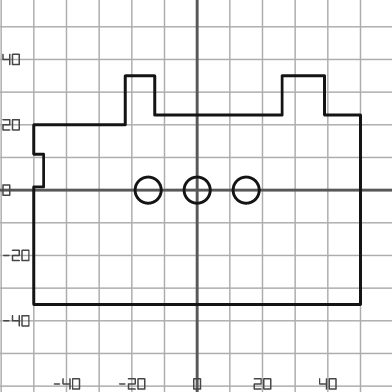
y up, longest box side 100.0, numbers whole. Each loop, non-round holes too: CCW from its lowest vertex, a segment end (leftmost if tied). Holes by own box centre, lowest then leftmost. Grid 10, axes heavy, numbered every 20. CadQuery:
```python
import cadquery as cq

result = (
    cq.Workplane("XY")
    .moveTo(-50.0, -35.0)
    .lineTo(50.0, -35.0)
    .lineTo(50.0, 23.0)
    .lineTo(39.0, 23.0)
    .lineTo(39.0, 35.0)
    .lineTo(26.0, 35.0)
    .lineTo(26.0, 23.0)
    .lineTo(-13.0, 23.0)
    .lineTo(-13.0, 35.0)
    .lineTo(-22.0, 35.0)
    .lineTo(-22.0, 20.0)
    .lineTo(-50.0, 20.0)
    .lineTo(-50.0, 11.0)
    .lineTo(-47.0, 11.0)
    .lineTo(-47.0, 1.0)
    .lineTo(-50.0, 1.0)
    .close()
    .moveTo(-15.0, 0.0)
    .circle(4.0)
    .moveTo(0.0, 0.0)
    .circle(4.0)
    .moveTo(15.0, 0.0)
    .circle(4.0)
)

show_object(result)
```